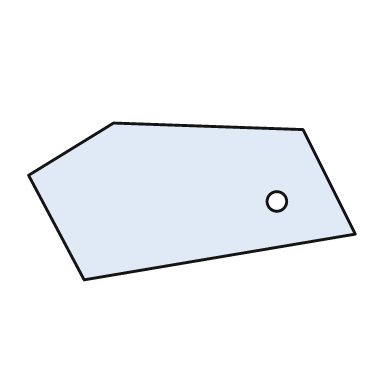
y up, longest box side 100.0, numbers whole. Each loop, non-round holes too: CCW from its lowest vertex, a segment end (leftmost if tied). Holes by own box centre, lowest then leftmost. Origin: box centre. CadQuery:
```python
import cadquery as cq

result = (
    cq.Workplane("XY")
    .moveTo(-33.0, -24.0)
    .lineTo(50.0, -10.0)
    .lineTo(34.0, 22.0)
    .lineTo(-24.0, 24.0)
    .lineTo(-50.0, 8.0)
    .close()
    .moveTo(26.0, 0.0)
    .circle(3.0)
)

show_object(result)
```